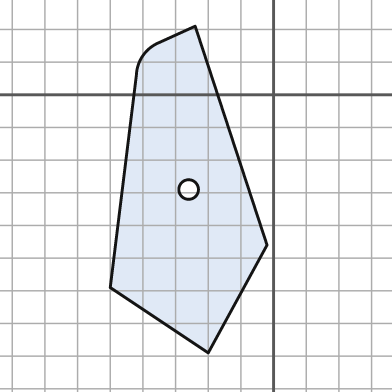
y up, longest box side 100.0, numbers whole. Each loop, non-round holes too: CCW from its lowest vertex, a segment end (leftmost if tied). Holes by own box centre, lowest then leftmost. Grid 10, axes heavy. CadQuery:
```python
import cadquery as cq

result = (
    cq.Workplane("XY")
    .moveTo(-20.0, -79.0)
    .lineTo(-2.0, -46.0)
    .lineTo(-24.0, 21.0)
    .lineTo(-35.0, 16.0)
    .threePointArc((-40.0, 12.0), (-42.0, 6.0))
    .lineTo(-50.0, -59.0)
    .close()
    .moveTo(-26.0, -29.0)
    .circle(3.0)
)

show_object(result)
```